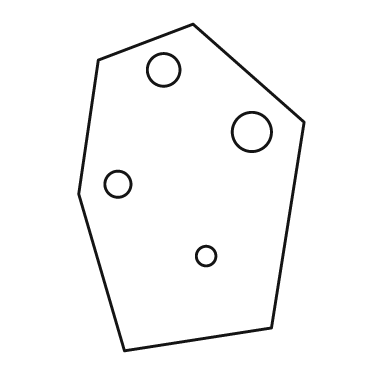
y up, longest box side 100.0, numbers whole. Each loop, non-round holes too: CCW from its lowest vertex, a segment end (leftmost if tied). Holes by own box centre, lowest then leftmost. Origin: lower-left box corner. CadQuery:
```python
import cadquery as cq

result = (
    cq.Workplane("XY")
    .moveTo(14.0, 0.0)
    .lineTo(59.0, 7.0)
    .lineTo(69.0, 70.0)
    .lineTo(35.0, 100.0)
    .lineTo(6.0, 89.0)
    .lineTo(0.0, 48.0)
    .close()
    .moveTo(39.0, 29.0)
    .circle(3.0)
    .moveTo(12.0, 51.0)
    .circle(4.0)
    .moveTo(53.0, 67.0)
    .circle(6.0)
    .moveTo(26.0, 86.0)
    .circle(5.0)
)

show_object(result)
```